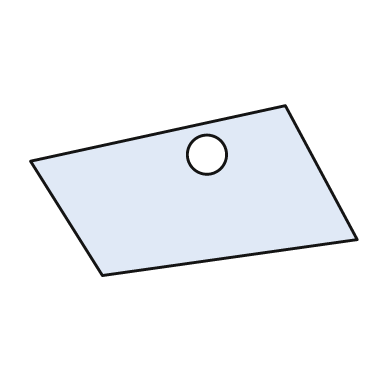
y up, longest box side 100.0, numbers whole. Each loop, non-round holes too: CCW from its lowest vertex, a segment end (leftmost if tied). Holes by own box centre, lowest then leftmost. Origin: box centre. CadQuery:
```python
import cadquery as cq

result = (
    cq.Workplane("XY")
    .moveTo(-28.0, -26.0)
    .lineTo(50.0, -15.0)
    .lineTo(28.0, 26.0)
    .lineTo(-50.0, 9.0)
    .close()
    .moveTo(4.0, 11.0)
    .circle(6.0)
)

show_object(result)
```